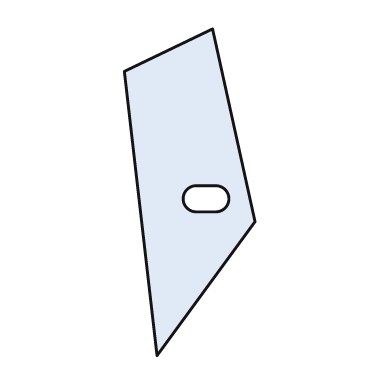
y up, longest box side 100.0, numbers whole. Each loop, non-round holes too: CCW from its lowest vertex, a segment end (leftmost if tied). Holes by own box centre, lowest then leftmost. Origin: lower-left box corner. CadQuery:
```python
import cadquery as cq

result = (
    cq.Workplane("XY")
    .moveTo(10.0, 0.0)
    .lineTo(40.0, 41.0)
    .lineTo(27.0, 100.0)
    .lineTo(0.0, 87.0)
    .close()
    .moveTo(22.0, 44.0)
    .lineTo(28.0, 44.0)
    .threePointArc((32.0, 48.0), (28.0, 52.0))
    .lineTo(22.0, 52.0)
    .threePointArc((18.0, 48.0), (22.0, 44.0))
    .close()
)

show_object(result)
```